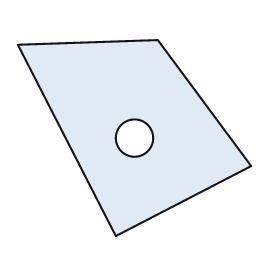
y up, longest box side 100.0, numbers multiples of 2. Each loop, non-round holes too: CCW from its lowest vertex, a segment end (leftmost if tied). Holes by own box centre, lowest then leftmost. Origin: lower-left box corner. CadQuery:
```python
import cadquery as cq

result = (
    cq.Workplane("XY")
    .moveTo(42.0, 0.0)
    .lineTo(100.0, 30.0)
    .lineTo(60.0, 84.0)
    .lineTo(0.0, 82.0)
    .close()
    .moveTo(50.0, 42.0)
    .circle(8.0)
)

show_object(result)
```